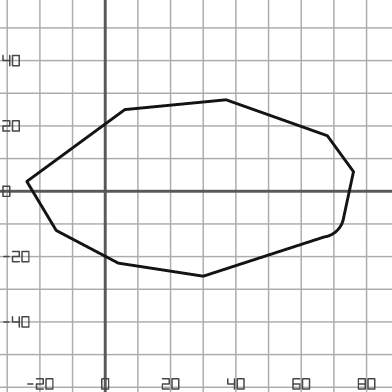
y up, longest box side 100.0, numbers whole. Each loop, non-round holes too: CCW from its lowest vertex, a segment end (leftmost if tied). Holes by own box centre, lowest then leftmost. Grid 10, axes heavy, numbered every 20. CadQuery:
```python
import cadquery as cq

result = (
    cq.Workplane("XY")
    .moveTo(30.0, -26.0)
    .lineTo(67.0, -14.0)
    .threePointArc((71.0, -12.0), (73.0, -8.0))
    .lineTo(76.0, 6.0)
    .lineTo(68.0, 17.0)
    .lineTo(37.0, 28.0)
    .lineTo(6.0, 25.0)
    .lineTo(-24.0, 3.0)
    .lineTo(-15.0, -12.0)
    .lineTo(4.0, -22.0)
    .close()
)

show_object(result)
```